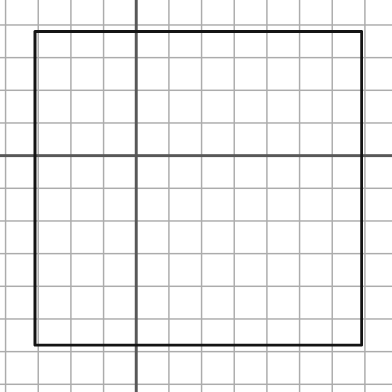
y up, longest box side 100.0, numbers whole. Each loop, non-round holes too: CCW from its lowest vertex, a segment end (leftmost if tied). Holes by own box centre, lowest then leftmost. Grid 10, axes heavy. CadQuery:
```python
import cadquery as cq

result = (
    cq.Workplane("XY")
    .moveTo(-31.0, -58.0)
    .lineTo(69.0, -58.0)
    .lineTo(69.0, 38.0)
    .lineTo(-31.0, 38.0)
    .close()
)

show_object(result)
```